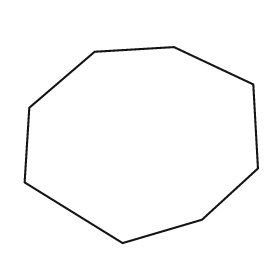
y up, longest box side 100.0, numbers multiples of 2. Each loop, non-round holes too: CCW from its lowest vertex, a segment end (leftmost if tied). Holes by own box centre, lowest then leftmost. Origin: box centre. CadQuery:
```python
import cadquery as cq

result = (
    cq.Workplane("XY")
    .moveTo(-8.0, -42.0)
    .lineTo(26.0, -32.0)
    .lineTo(50.0, -10.0)
    .lineTo(48.0, 26.0)
    .lineTo(14.0, 42.0)
    .lineTo(-20.0, 40.0)
    .lineTo(-48.0, 16.0)
    .lineTo(-50.0, -16.0)
    .close()
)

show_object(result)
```